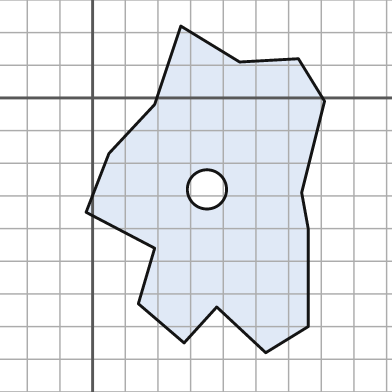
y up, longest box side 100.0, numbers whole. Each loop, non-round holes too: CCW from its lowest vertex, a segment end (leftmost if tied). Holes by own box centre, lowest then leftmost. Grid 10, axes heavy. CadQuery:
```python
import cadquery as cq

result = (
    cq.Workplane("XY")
    .moveTo(53.0, -78.0)
    .lineTo(66.0, -70.0)
    .lineTo(66.0, -40.0)
    .lineTo(64.0, -29.0)
    .lineTo(71.0, -1.0)
    .lineTo(63.0, 12.0)
    .lineTo(45.0, 11.0)
    .lineTo(27.0, 22.0)
    .lineTo(19.0, -2.0)
    .lineTo(5.0, -17.0)
    .lineTo(-2.0, -35.0)
    .lineTo(19.0, -46.0)
    .lineTo(14.0, -63.0)
    .lineTo(28.0, -75.0)
    .lineTo(38.0, -64.0)
    .close()
    .moveTo(35.0, -28.0)
    .circle(6.0)
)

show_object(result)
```